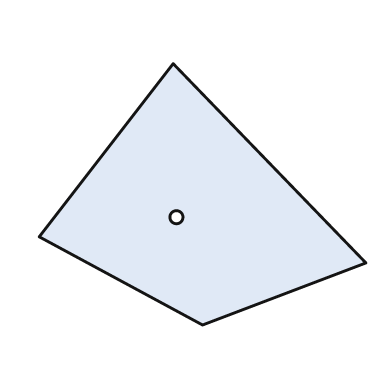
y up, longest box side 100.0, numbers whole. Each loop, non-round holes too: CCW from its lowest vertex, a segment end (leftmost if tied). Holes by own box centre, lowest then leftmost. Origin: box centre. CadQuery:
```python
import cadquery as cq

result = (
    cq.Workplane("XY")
    .moveTo(0.0, -40.0)
    .lineTo(50.0, -21.0)
    .lineTo(-9.0, 40.0)
    .lineTo(-50.0, -13.0)
    .close()
    .moveTo(-8.0, -7.0)
    .circle(2.0)
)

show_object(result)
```